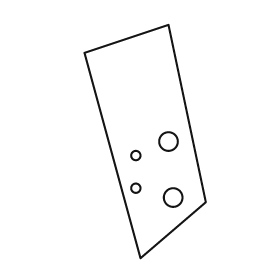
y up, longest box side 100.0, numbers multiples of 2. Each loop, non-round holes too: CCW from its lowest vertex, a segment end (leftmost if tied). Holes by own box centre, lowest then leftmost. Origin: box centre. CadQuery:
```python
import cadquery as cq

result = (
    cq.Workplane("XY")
    .moveTo(-2.0, -50.0)
    .lineTo(26.0, -26.0)
    .lineTo(10.0, 50.0)
    .lineTo(-26.0, 38.0)
    .close()
    .moveTo(12.0, -24.0)
    .circle(4.0)
    .moveTo(-4.0, -20.0)
    .circle(2.0)
    .moveTo(-4.0, -6.0)
    .circle(2.0)
    .moveTo(10.0, 0.0)
    .circle(4.0)
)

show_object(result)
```